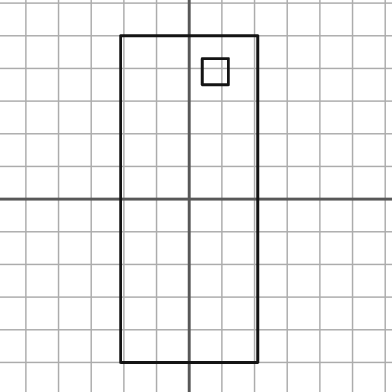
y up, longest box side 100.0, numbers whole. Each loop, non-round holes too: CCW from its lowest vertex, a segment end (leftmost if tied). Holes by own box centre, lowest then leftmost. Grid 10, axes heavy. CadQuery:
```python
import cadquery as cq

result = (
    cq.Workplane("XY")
    .moveTo(-21.0, -50.0)
    .lineTo(21.0, -50.0)
    .lineTo(21.0, 50.0)
    .lineTo(-21.0, 50.0)
    .close()
    .moveTo(4.0, 35.0)
    .lineTo(12.0, 35.0)
    .lineTo(12.0, 43.0)
    .lineTo(4.0, 43.0)
    .close()
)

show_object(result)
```